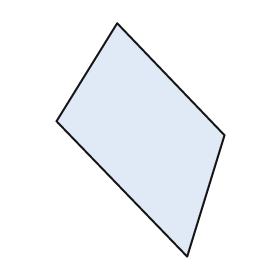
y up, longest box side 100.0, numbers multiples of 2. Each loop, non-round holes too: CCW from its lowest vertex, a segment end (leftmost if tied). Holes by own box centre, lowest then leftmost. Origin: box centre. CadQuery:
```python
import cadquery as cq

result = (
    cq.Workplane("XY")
    .moveTo(20.0, -50.0)
    .lineTo(36.0, 2.0)
    .lineTo(-10.0, 50.0)
    .lineTo(-36.0, 8.0)
    .close()
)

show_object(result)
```